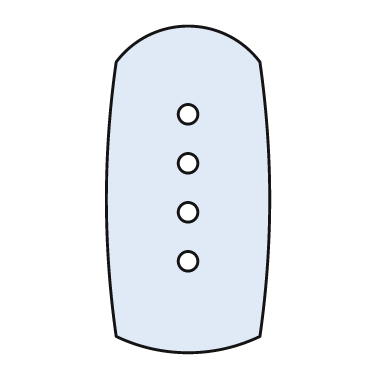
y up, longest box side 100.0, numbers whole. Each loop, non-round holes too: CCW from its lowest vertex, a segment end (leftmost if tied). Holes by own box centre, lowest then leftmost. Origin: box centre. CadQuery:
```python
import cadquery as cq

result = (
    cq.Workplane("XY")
    .moveTo(-22.0, -45.0)
    .threePointArc((0.0, -50.0), (22.0, -45.0))
    .threePointArc((25.0, -3.0), (22.0, 39.0))
    .threePointArc((0.0, 50.0), (-22.0, 39.0))
    .threePointArc((-25.0, -3.0), (-22.0, -45.0))
    .close()
    .moveTo(0.0, -22.0)
    .circle(3.0)
    .moveTo(0.0, -7.0)
    .circle(3.0)
    .moveTo(0.0, 8.0)
    .circle(3.0)
    .moveTo(0.0, 23.0)
    .circle(3.0)
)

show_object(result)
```